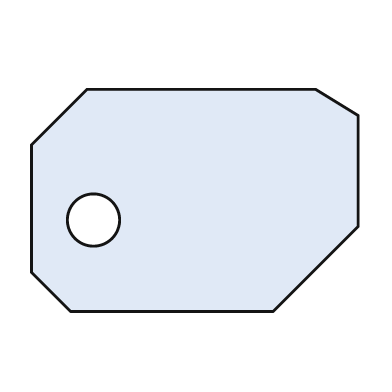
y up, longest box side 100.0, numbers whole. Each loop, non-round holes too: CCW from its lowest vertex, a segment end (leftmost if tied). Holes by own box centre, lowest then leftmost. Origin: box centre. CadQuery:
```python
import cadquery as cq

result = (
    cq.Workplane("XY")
    .moveTo(-38.0, -34.0)
    .lineTo(24.0, -34.0)
    .lineTo(50.0, -8.0)
    .lineTo(50.0, 26.0)
    .lineTo(37.0, 34.0)
    .lineTo(-33.0, 34.0)
    .lineTo(-50.0, 17.0)
    .lineTo(-50.0, -22.0)
    .close()
    .moveTo(-31.0, -6.0)
    .circle(8.0)
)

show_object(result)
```